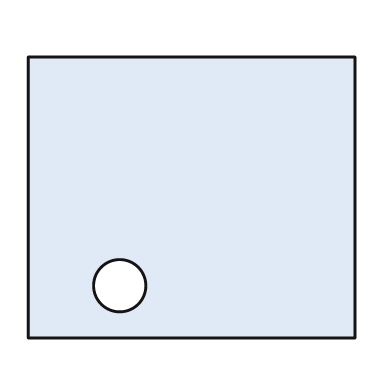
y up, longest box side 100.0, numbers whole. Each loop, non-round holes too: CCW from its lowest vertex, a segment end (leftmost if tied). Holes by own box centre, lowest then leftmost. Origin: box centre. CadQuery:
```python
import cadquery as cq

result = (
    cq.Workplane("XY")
    .moveTo(-50.0, -43.0)
    .lineTo(50.0, -43.0)
    .lineTo(50.0, 43.0)
    .lineTo(-50.0, 43.0)
    .close()
    .moveTo(-22.0, -27.0)
    .circle(8.0)
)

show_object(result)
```